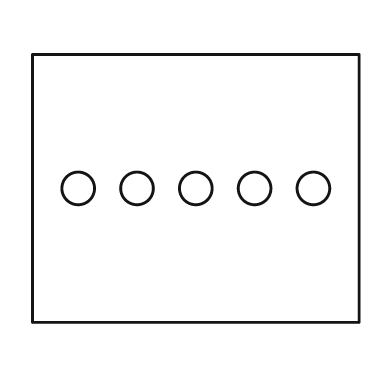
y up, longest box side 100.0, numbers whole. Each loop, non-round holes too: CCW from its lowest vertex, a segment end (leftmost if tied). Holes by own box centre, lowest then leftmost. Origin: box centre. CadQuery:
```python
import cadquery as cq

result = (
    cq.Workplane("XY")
    .moveTo(-50.0, -41.0)
    .lineTo(50.0, -41.0)
    .lineTo(50.0, 41.0)
    .lineTo(-50.0, 41.0)
    .close()
    .moveTo(-36.0, 0.0)
    .circle(5.0)
    .moveTo(-18.0, 0.0)
    .circle(5.0)
    .moveTo(0.0, 0.0)
    .circle(5.0)
    .moveTo(18.0, 0.0)
    .circle(5.0)
    .moveTo(36.0, 0.0)
    .circle(5.0)
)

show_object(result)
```